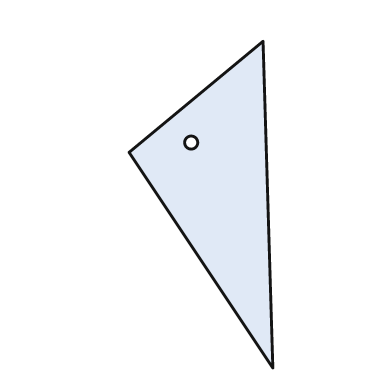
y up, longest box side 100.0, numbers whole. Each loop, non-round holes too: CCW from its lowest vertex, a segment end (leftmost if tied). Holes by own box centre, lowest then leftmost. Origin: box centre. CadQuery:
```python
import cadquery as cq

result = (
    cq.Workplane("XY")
    .moveTo(22.0, -50.0)
    .lineTo(19.0, 50.0)
    .lineTo(-22.0, 16.0)
    .close()
    .moveTo(-3.0, 19.0)
    .circle(2.0)
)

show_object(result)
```